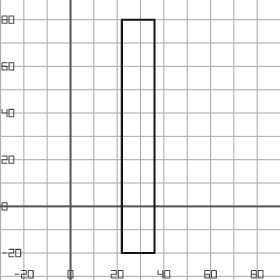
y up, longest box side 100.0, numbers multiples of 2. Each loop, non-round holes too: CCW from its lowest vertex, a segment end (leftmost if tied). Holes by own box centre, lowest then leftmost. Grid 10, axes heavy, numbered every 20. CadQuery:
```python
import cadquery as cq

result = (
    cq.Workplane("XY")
    .moveTo(22.0, -20.0)
    .lineTo(36.0, -20.0)
    .lineTo(36.0, 80.0)
    .lineTo(22.0, 80.0)
    .close()
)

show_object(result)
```